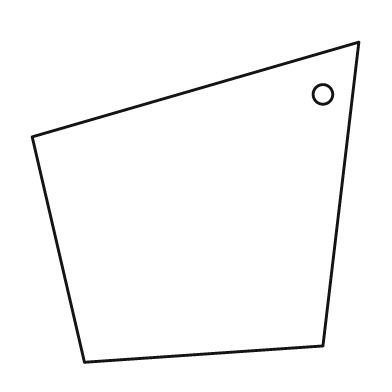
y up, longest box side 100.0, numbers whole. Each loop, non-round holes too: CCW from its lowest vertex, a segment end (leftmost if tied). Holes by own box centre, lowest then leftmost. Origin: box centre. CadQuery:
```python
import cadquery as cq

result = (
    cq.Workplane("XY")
    .moveTo(-34.0, -49.0)
    .lineTo(39.0, -44.0)
    .lineTo(50.0, 49.0)
    .lineTo(-50.0, 20.0)
    .close()
    .moveTo(39.0, 33.0)
    .circle(3.0)
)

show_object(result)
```